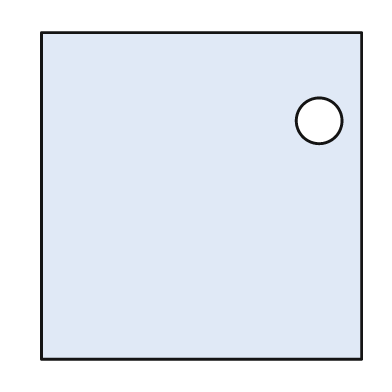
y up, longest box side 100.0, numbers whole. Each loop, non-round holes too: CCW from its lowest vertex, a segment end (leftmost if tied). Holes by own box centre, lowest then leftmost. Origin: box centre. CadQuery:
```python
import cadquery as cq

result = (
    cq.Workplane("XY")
    .moveTo(-49.0, -50.0)
    .lineTo(49.0, -50.0)
    .lineTo(49.0, 50.0)
    .lineTo(-49.0, 50.0)
    .close()
    .moveTo(36.0, 23.0)
    .circle(7.0)
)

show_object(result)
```